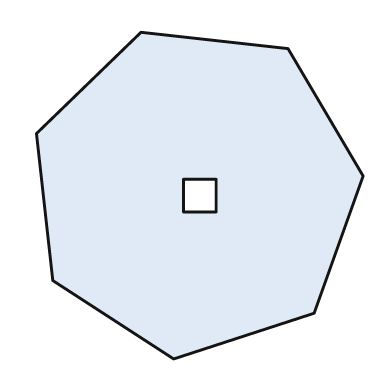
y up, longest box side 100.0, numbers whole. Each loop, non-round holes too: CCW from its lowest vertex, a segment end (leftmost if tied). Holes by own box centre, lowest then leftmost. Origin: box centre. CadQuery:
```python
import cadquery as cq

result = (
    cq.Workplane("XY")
    .moveTo(-8.0, -50.0)
    .lineTo(35.0, -36.0)
    .lineTo(50.0, 6.0)
    .lineTo(27.0, 45.0)
    .lineTo(-18.0, 50.0)
    .lineTo(-50.0, 19.0)
    .lineTo(-45.0, -26.0)
    .close()
    .moveTo(-5.0, -5.0)
    .lineTo(5.0, -5.0)
    .lineTo(5.0, 5.0)
    .lineTo(-5.0, 5.0)
    .close()
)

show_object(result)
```